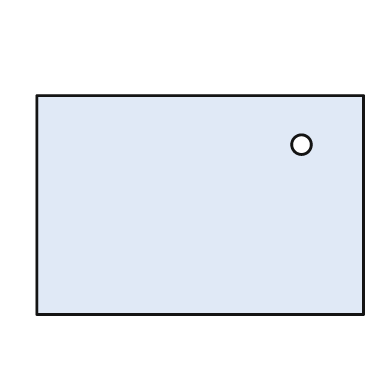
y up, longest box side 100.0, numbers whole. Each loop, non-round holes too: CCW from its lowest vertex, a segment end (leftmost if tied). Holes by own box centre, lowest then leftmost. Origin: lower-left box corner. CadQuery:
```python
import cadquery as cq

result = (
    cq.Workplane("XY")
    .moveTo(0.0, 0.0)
    .lineTo(100.0, 0.0)
    .lineTo(100.0, 67.0)
    .lineTo(0.0, 67.0)
    .close()
    .moveTo(81.0, 52.0)
    .circle(3.0)
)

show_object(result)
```